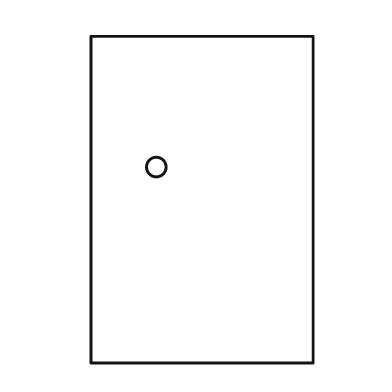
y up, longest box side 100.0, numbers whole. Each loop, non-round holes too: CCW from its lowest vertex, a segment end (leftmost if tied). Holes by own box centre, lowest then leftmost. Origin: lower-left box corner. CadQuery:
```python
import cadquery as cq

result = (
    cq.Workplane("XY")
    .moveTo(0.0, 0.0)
    .lineTo(68.0, 0.0)
    .lineTo(68.0, 100.0)
    .lineTo(0.0, 100.0)
    .close()
    .moveTo(20.0, 60.0)
    .circle(3.0)
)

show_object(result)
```